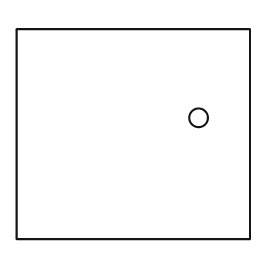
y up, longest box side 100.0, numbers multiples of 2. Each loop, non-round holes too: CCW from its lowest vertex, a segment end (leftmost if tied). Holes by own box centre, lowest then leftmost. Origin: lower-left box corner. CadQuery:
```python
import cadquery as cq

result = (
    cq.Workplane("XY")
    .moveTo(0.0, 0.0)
    .lineTo(100.0, 0.0)
    .lineTo(100.0, 90.0)
    .lineTo(0.0, 90.0)
    .close()
    .moveTo(78.0, 52.0)
    .circle(4.0)
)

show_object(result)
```